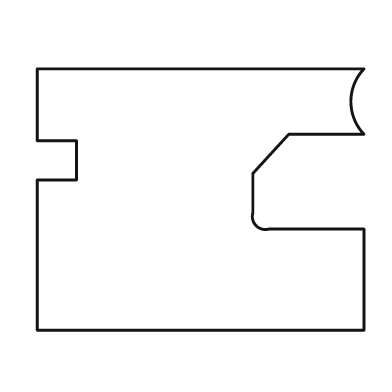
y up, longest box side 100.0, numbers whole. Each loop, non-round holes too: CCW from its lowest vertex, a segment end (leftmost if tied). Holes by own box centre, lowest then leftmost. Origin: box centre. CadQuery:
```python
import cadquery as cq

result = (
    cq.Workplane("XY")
    .moveTo(-50.0, -40.0)
    .lineTo(50.0, -40.0)
    .lineTo(50.0, -9.0)
    .lineTo(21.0, -9.0)
    .threePointArc((17.0, -8.0), (16.0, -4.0))
    .lineTo(16.0, 8.0)
    .lineTo(27.0, 20.0)
    .lineTo(50.0, 20.0)
    .threePointArc((46.0, 30.0), (50.0, 40.0))
    .lineTo(-50.0, 40.0)
    .lineTo(-50.0, 18.0)
    .lineTo(-38.0, 18.0)
    .lineTo(-38.0, 6.0)
    .lineTo(-50.0, 6.0)
    .close()
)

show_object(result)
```